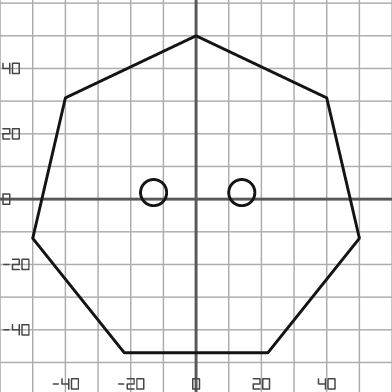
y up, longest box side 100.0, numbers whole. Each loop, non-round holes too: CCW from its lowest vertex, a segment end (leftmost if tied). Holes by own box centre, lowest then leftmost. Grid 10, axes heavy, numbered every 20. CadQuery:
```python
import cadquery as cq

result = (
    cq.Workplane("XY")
    .moveTo(-22.0, -47.0)
    .lineTo(22.0, -47.0)
    .lineTo(50.0, -12.0)
    .lineTo(40.0, 31.0)
    .lineTo(0.0, 50.0)
    .lineTo(-40.0, 31.0)
    .lineTo(-50.0, -12.0)
    .close()
    .moveTo(-13.0, 2.0)
    .circle(4.0)
    .moveTo(14.0, 2.0)
    .circle(4.0)
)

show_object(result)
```